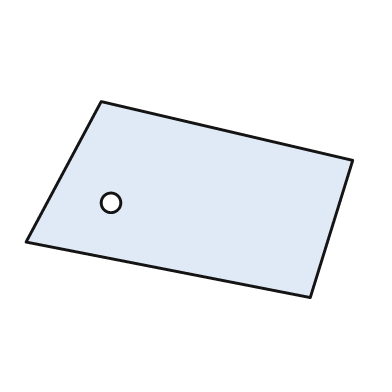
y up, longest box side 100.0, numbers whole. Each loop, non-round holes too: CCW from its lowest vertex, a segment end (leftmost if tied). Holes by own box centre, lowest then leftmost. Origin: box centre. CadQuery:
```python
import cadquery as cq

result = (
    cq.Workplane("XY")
    .moveTo(37.0, -30.0)
    .lineTo(50.0, 12.0)
    .lineTo(-27.0, 30.0)
    .lineTo(-50.0, -13.0)
    .close()
    .moveTo(-24.0, -1.0)
    .circle(3.0)
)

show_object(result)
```